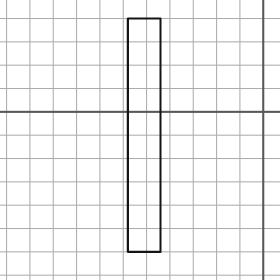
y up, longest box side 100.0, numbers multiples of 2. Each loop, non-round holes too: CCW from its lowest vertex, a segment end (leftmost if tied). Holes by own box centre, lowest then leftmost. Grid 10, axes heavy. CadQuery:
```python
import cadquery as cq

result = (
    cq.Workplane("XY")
    .moveTo(-58.0, -60.0)
    .lineTo(-44.0, -60.0)
    .lineTo(-44.0, 40.0)
    .lineTo(-58.0, 40.0)
    .close()
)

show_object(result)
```